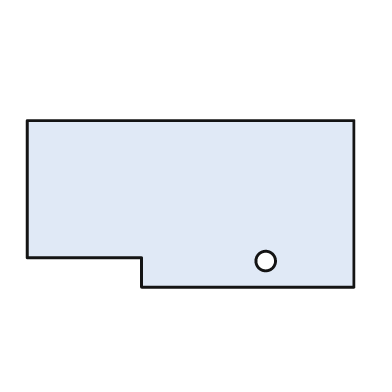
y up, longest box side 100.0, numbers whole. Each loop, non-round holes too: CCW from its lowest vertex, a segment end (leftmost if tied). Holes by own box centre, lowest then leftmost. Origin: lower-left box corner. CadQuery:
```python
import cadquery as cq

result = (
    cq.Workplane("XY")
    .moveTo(35.0, 0.0)
    .lineTo(100.0, 0.0)
    .lineTo(100.0, 51.0)
    .lineTo(0.0, 51.0)
    .lineTo(0.0, 9.0)
    .lineTo(35.0, 9.0)
    .close()
    .moveTo(73.0, 8.0)
    .circle(3.0)
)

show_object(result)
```